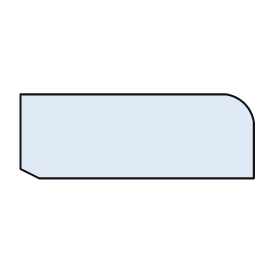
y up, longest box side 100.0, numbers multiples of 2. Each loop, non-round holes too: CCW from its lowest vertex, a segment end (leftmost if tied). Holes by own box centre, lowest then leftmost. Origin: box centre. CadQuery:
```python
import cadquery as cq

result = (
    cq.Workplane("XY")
    .moveTo(-42.0, -18.0)
    .lineTo(50.0, -18.0)
    .lineTo(50.0, 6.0)
    .threePointArc((46.0, 14.0), (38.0, 18.0))
    .lineTo(-50.0, 18.0)
    .lineTo(-50.0, -14.0)
    .close()
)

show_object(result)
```